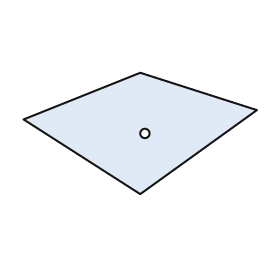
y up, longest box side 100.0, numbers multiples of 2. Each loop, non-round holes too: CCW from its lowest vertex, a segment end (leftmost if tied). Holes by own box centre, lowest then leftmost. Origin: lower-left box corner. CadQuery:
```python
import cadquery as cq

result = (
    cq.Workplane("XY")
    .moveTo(50.0, 0.0)
    .lineTo(100.0, 36.0)
    .lineTo(50.0, 52.0)
    .lineTo(0.0, 32.0)
    .close()
    .moveTo(52.0, 26.0)
    .circle(2.0)
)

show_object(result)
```